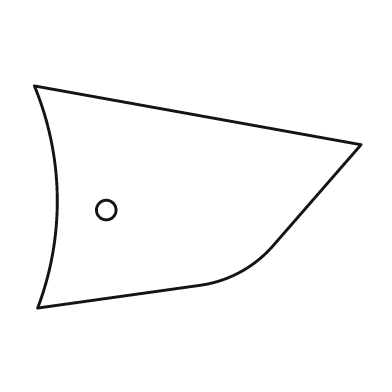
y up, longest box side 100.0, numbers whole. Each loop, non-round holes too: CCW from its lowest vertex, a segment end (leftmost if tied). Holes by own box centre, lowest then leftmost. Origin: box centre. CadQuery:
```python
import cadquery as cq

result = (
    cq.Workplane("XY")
    .moveTo(-49.0, -34.0)
    .lineTo(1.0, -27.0)
    .threePointArc((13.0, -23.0), (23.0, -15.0))
    .lineTo(50.0, 16.0)
    .lineTo(-50.0, 34.0)
    .threePointArc((-43.0, 0.0), (-49.0, -34.0))
    .close()
    .moveTo(-28.0, -4.0)
    .circle(3.0)
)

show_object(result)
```